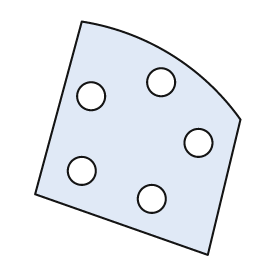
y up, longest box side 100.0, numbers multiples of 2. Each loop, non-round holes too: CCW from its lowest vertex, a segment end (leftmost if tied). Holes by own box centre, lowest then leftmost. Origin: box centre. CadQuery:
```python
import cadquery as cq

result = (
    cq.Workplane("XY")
    .moveTo(30.0, -50.0)
    .lineTo(44.0, 8.0)
    .threePointArc((14.0, 36.0), (-24.0, 50.0))
    .lineTo(-44.0, -24.0)
    .close()
    .moveTo(6.0, -26.0)
    .circle(6.0)
    .moveTo(-24.0, -14.0)
    .circle(6.0)
    .moveTo(26.0, -2.0)
    .circle(6.0)
    .moveTo(-20.0, 18.0)
    .circle(6.0)
    .moveTo(10.0, 24.0)
    .circle(6.0)
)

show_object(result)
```